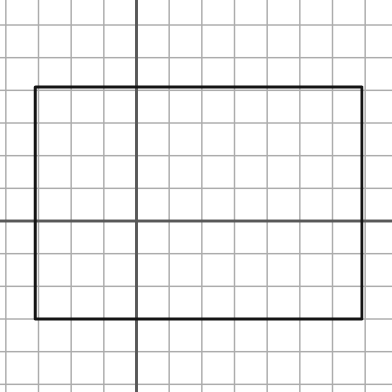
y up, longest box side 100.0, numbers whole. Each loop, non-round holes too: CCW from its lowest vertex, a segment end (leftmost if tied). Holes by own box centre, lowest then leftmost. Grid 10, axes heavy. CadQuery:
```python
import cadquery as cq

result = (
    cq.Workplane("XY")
    .moveTo(-31.0, -30.0)
    .lineTo(69.0, -30.0)
    .lineTo(69.0, 41.0)
    .lineTo(-31.0, 41.0)
    .close()
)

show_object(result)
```